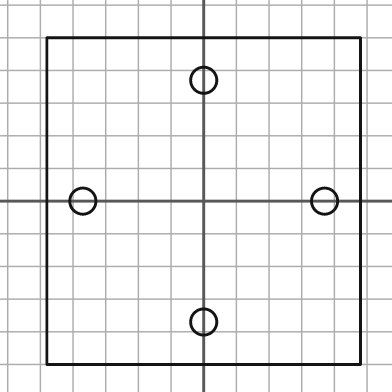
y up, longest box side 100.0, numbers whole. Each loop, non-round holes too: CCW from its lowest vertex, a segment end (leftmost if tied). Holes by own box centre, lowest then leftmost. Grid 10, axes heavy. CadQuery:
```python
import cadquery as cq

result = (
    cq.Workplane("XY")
    .moveTo(-48.0, -50.0)
    .lineTo(48.0, -50.0)
    .lineTo(48.0, 50.0)
    .lineTo(-48.0, 50.0)
    .close()
    .moveTo(0.0, -37.0)
    .circle(4.0)
    .moveTo(-37.0, 0.0)
    .circle(4.0)
    .moveTo(37.0, 0.0)
    .circle(4.0)
    .moveTo(0.0, 37.0)
    .circle(4.0)
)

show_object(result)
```